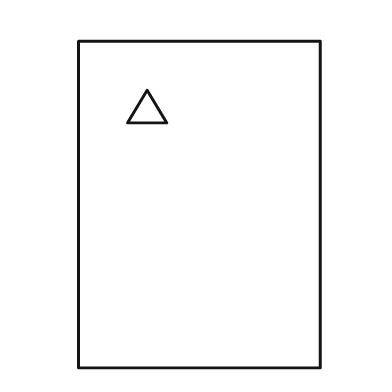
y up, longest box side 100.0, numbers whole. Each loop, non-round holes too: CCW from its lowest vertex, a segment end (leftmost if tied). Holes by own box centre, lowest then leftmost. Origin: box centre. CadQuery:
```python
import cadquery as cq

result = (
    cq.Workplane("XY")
    .moveTo(-37.0, -50.0)
    .lineTo(37.0, -50.0)
    .lineTo(37.0, 50.0)
    .lineTo(-37.0, 50.0)
    .close()
    .moveTo(-22.0, 25.0)
    .lineTo(-10.0, 25.0)
    .lineTo(-16.0, 35.0)
    .close()
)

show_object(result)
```